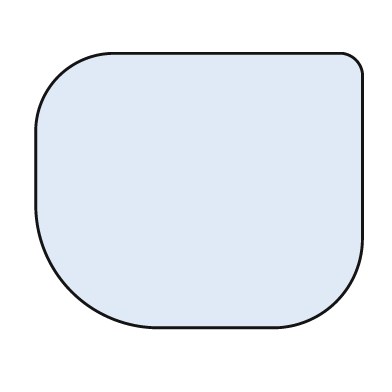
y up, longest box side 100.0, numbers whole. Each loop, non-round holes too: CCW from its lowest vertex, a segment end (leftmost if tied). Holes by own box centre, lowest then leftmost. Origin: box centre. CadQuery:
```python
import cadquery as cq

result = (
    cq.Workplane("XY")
    .moveTo(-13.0, -42.0)
    .lineTo(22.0, -42.0)
    .threePointArc((42.0, -34.0), (50.0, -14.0))
    .lineTo(50.0, 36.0)
    .threePointArc((48.0, 40.0), (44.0, 42.0))
    .lineTo(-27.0, 42.0)
    .threePointArc((-43.0, 35.0), (-50.0, 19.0))
    .lineTo(-50.0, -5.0)
    .threePointArc((-39.0, -31.0), (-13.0, -42.0))
    .close()
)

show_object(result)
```